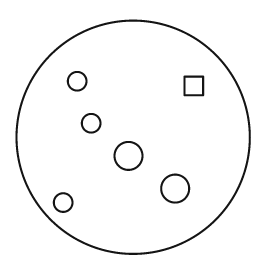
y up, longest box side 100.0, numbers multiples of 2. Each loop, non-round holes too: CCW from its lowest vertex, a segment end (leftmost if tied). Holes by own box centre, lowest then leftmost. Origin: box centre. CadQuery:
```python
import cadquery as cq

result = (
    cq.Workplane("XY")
    .moveTo(0.0, 0.0)
    .circle(50.0)
    .moveTo(-30.0, -28.0)
    .circle(4.0)
    .moveTo(18.0, -22.0)
    .circle(6.0)
    .moveTo(-2.0, -8.0)
    .circle(6.0)
    .moveTo(-18.0, 6.0)
    .circle(4.0)
    .moveTo(22.0, 18.0)
    .lineTo(30.0, 18.0)
    .lineTo(30.0, 26.0)
    .lineTo(22.0, 26.0)
    .close()
    .moveTo(-24.0, 24.0)
    .circle(4.0)
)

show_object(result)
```